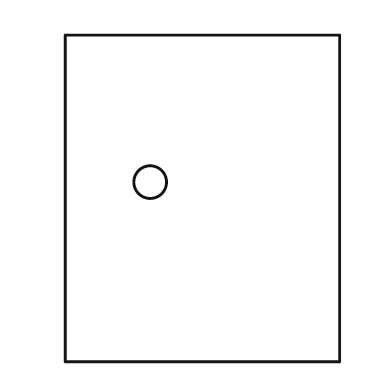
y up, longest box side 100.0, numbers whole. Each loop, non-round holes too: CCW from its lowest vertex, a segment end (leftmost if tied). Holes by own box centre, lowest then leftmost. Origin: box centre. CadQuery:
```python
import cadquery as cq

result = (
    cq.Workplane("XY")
    .moveTo(-42.0, -50.0)
    .lineTo(42.0, -50.0)
    .lineTo(42.0, 50.0)
    .lineTo(-42.0, 50.0)
    .close()
    .moveTo(-16.0, 5.0)
    .circle(5.0)
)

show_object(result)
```